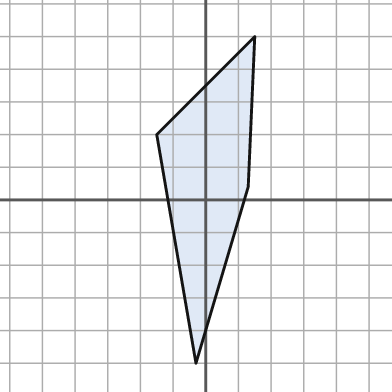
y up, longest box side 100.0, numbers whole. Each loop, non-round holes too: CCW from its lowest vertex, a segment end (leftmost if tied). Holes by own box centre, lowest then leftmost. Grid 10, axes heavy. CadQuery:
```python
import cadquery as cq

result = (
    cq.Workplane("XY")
    .moveTo(-3.0, -50.0)
    .lineTo(13.0, 4.0)
    .lineTo(15.0, 50.0)
    .lineTo(-15.0, 20.0)
    .close()
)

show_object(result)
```